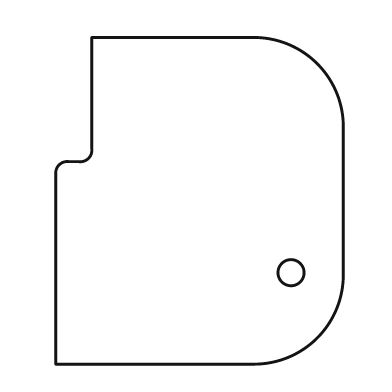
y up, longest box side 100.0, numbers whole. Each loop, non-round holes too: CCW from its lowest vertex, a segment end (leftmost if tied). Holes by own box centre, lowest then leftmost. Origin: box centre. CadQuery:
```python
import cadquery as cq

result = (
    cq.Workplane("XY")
    .moveTo(-44.0, -50.0)
    .lineTo(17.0, -50.0)
    .threePointArc((36.0, -42.0), (44.0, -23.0))
    .lineTo(44.0, 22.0)
    .threePointArc((36.0, 42.0), (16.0, 50.0))
    .lineTo(-33.0, 50.0)
    .lineTo(-33.0, 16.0)
    .threePointArc((-34.0, 13.0), (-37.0, 12.0))
    .lineTo(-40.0, 12.0)
    .threePointArc((-43.0, 11.0), (-44.0, 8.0))
    .close()
    .moveTo(28.0, -22.0)
    .circle(4.0)
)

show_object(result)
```